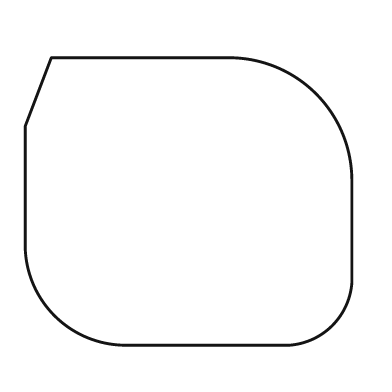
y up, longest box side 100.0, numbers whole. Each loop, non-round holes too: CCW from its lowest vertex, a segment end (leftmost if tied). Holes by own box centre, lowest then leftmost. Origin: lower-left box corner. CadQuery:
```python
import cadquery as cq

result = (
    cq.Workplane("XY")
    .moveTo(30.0, 0.0)
    .lineTo(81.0, 0.0)
    .threePointArc((94.0, 6.0), (100.0, 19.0))
    .lineTo(100.0, 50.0)
    .threePointArc((89.0, 77.0), (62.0, 88.0))
    .lineTo(8.0, 88.0)
    .lineTo(0.0, 67.0)
    .lineTo(0.0, 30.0)
    .threePointArc((9.0, 9.0), (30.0, 0.0))
    .close()
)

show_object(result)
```